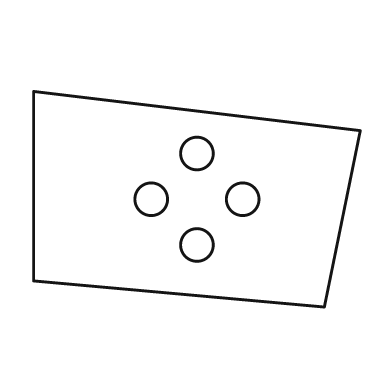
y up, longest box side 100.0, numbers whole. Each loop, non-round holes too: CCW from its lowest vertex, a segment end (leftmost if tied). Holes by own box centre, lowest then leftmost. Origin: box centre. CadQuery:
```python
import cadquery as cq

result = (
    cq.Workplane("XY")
    .moveTo(39.0, -33.0)
    .lineTo(50.0, 21.0)
    .lineTo(-50.0, 33.0)
    .lineTo(-50.0, -25.0)
    .close()
    .moveTo(0.0, -14.0)
    .circle(5.0)
    .moveTo(-14.0, 0.0)
    .circle(5.0)
    .moveTo(14.0, 0.0)
    .circle(5.0)
    .moveTo(0.0, 14.0)
    .circle(5.0)
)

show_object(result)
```